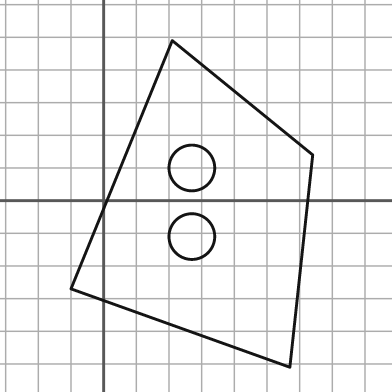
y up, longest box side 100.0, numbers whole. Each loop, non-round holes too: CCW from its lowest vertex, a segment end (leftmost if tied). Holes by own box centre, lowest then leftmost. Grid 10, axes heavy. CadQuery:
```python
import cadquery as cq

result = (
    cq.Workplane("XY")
    .moveTo(57.0, -51.0)
    .lineTo(64.0, 14.0)
    .lineTo(21.0, 49.0)
    .lineTo(-10.0, -27.0)
    .close()
    .moveTo(27.0, -11.0)
    .circle(7.0)
    .moveTo(27.0, 10.0)
    .circle(7.0)
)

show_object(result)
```